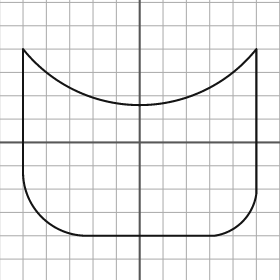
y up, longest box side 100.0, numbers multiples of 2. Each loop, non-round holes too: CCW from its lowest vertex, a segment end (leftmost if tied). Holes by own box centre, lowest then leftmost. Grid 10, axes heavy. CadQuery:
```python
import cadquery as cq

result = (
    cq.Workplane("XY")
    .moveTo(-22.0, -40.0)
    .lineTo(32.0, -40.0)
    .threePointArc((44.0, -34.0), (50.0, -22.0))
    .lineTo(50.0, 40.0)
    .threePointArc((0.0, 16.0), (-50.0, 40.0))
    .lineTo(-50.0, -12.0)
    .threePointArc((-42.0, -32.0), (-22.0, -40.0))
    .close()
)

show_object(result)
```